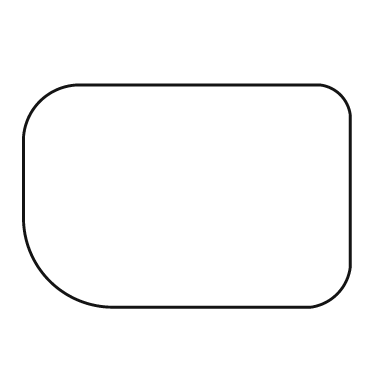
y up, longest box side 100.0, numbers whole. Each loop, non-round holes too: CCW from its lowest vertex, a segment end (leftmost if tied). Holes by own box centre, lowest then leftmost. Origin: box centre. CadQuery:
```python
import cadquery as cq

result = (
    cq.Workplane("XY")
    .moveTo(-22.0, -34.0)
    .lineTo(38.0, -34.0)
    .threePointArc((46.0, -30.0), (50.0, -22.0))
    .lineTo(50.0, 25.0)
    .threePointArc((47.0, 31.0), (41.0, 34.0))
    .lineTo(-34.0, 34.0)
    .threePointArc((-45.0, 29.0), (-50.0, 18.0))
    .lineTo(-50.0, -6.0)
    .threePointArc((-42.0, -26.0), (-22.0, -34.0))
    .close()
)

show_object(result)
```